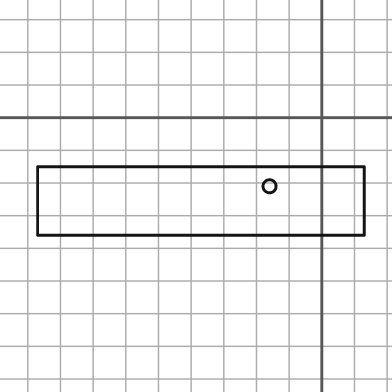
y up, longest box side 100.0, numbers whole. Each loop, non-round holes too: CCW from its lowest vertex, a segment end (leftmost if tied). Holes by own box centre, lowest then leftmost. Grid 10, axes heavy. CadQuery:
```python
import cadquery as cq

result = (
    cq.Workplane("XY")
    .moveTo(-87.0, -36.0)
    .lineTo(13.0, -36.0)
    .lineTo(13.0, -15.0)
    .lineTo(-87.0, -15.0)
    .close()
    .moveTo(-16.0, -21.0)
    .circle(2.0)
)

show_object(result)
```